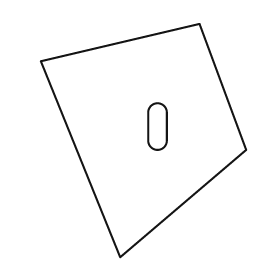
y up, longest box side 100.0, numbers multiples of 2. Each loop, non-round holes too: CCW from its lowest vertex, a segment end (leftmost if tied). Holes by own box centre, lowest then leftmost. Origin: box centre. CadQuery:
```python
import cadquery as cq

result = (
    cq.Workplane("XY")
    .moveTo(-10.0, -50.0)
    .lineTo(44.0, -4.0)
    .lineTo(24.0, 50.0)
    .lineTo(-44.0, 34.0)
    .close()
    .moveTo(2.0, 0.0)
    .threePointArc((6.0, -4.0), (10.0, 0.0))
    .lineTo(10.0, 12.0)
    .threePointArc((6.0, 16.0), (2.0, 12.0))
    .close()
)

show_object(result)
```